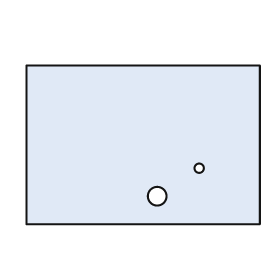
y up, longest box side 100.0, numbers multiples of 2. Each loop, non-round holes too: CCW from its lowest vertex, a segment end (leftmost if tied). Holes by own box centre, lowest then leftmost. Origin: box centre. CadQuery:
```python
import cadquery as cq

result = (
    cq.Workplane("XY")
    .moveTo(-50.0, -34.0)
    .lineTo(50.0, -34.0)
    .lineTo(50.0, 34.0)
    .lineTo(-50.0, 34.0)
    .close()
    .moveTo(6.0, -22.0)
    .circle(4.0)
    .moveTo(24.0, -10.0)
    .circle(2.0)
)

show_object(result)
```